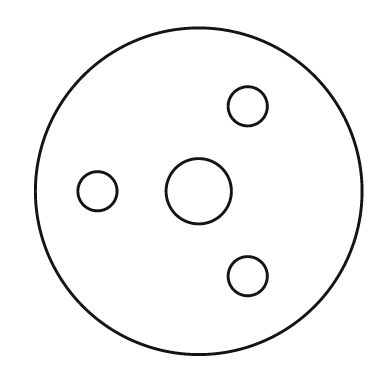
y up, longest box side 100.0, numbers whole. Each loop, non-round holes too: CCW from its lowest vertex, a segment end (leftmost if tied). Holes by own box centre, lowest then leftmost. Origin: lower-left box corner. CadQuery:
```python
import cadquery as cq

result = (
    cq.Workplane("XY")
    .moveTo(50.0, 50.0)
    .circle(50.0)
    .moveTo(65.0, 24.0)
    .circle(6.0)
    .moveTo(19.0, 50.0)
    .circle(6.0)
    .moveTo(50.0, 50.0)
    .circle(10.0)
    .moveTo(65.0, 76.0)
    .circle(6.0)
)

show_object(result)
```